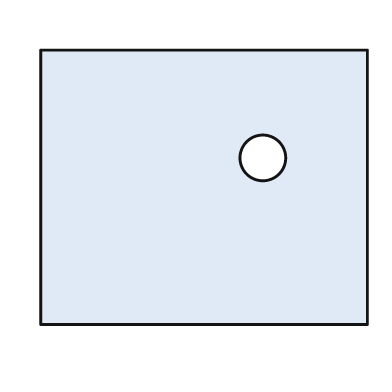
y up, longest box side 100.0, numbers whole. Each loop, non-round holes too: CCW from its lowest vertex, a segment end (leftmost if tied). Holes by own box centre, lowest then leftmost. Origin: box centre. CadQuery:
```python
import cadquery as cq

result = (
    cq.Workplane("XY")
    .moveTo(-50.0, -42.0)
    .lineTo(50.0, -42.0)
    .lineTo(50.0, 42.0)
    .lineTo(-50.0, 42.0)
    .close()
    .moveTo(18.0, 9.0)
    .circle(7.0)
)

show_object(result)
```